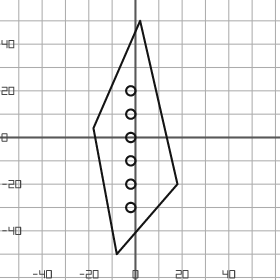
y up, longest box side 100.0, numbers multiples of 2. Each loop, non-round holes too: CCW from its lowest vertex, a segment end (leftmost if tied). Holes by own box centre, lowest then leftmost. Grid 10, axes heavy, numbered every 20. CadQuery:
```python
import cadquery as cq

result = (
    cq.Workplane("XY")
    .moveTo(-8.0, -50.0)
    .lineTo(18.0, -20.0)
    .lineTo(2.0, 50.0)
    .lineTo(-18.0, 4.0)
    .close()
    .moveTo(-2.0, -30.0)
    .circle(2.0)
    .moveTo(-2.0, -20.0)
    .circle(2.0)
    .moveTo(-2.0, -10.0)
    .circle(2.0)
    .moveTo(-2.0, 0.0)
    .circle(2.0)
    .moveTo(-2.0, 10.0)
    .circle(2.0)
    .moveTo(-2.0, 20.0)
    .circle(2.0)
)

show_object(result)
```